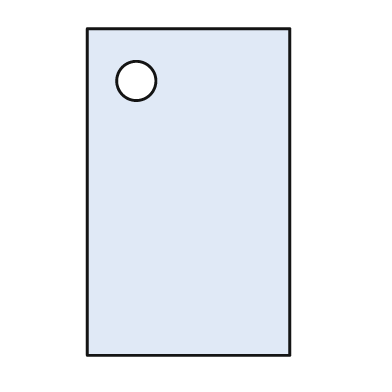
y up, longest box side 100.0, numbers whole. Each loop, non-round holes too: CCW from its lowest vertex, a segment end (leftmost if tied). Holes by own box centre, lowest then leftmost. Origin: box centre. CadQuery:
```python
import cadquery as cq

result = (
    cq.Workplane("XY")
    .moveTo(-31.0, -50.0)
    .lineTo(31.0, -50.0)
    .lineTo(31.0, 50.0)
    .lineTo(-31.0, 50.0)
    .close()
    .moveTo(-16.0, 34.0)
    .circle(6.0)
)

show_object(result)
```